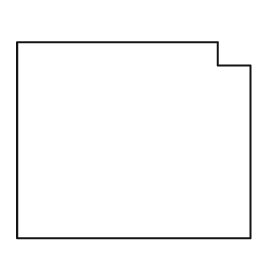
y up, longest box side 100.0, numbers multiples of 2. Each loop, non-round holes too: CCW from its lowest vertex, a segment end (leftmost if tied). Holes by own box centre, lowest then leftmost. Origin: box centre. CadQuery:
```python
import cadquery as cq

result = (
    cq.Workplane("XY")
    .moveTo(-50.0, -42.0)
    .lineTo(50.0, -42.0)
    .lineTo(50.0, 32.0)
    .lineTo(36.0, 32.0)
    .lineTo(36.0, 42.0)
    .lineTo(-50.0, 42.0)
    .close()
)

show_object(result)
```